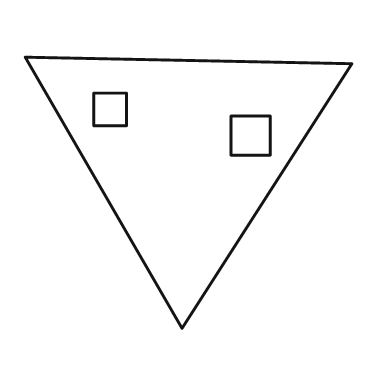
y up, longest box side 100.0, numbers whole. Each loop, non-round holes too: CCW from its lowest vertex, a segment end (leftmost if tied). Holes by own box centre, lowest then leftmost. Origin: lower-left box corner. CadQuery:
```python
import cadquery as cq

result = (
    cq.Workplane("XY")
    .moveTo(48.0, 0.0)
    .lineTo(100.0, 81.0)
    .lineTo(0.0, 83.0)
    .close()
    .moveTo(63.0, 53.0)
    .lineTo(75.0, 53.0)
    .lineTo(75.0, 65.0)
    .lineTo(63.0, 65.0)
    .close()
    .moveTo(21.0, 62.0)
    .lineTo(31.0, 62.0)
    .lineTo(31.0, 72.0)
    .lineTo(21.0, 72.0)
    .close()
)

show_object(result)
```